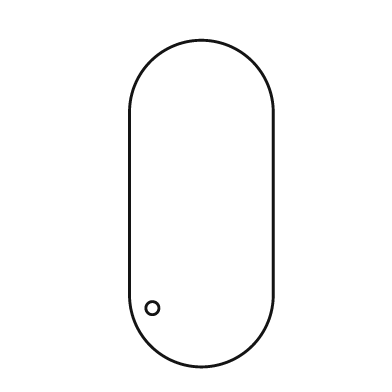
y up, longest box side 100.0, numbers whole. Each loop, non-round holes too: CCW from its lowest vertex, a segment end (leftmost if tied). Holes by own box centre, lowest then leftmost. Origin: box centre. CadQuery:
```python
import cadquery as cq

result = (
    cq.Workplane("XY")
    .moveTo(-22.0, -28.0)
    .threePointArc((0.0, -50.0), (22.0, -28.0))
    .lineTo(22.0, 28.0)
    .threePointArc((0.0, 50.0), (-22.0, 28.0))
    .close()
    .moveTo(-15.0, -32.0)
    .circle(2.0)
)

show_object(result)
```